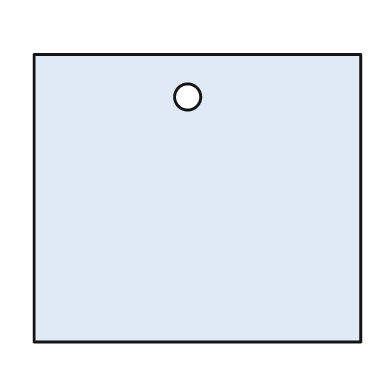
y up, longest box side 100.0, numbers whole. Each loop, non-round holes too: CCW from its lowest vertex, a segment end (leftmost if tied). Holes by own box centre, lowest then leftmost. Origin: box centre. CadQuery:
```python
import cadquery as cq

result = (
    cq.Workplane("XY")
    .moveTo(-50.0, -44.0)
    .lineTo(50.0, -44.0)
    .lineTo(50.0, 44.0)
    .lineTo(-50.0, 44.0)
    .close()
    .moveTo(-3.0, 31.0)
    .circle(4.0)
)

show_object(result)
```